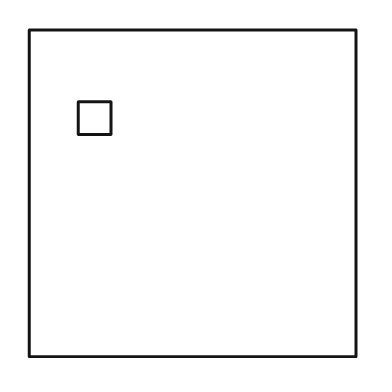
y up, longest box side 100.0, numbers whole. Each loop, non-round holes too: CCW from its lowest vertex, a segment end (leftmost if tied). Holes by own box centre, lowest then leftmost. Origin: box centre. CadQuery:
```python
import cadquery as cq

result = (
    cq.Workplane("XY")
    .moveTo(-50.0, -50.0)
    .lineTo(50.0, -50.0)
    .lineTo(50.0, 50.0)
    .lineTo(-50.0, 50.0)
    .close()
    .moveTo(-35.0, 18.0)
    .lineTo(-25.0, 18.0)
    .lineTo(-25.0, 28.0)
    .lineTo(-35.0, 28.0)
    .close()
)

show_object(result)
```